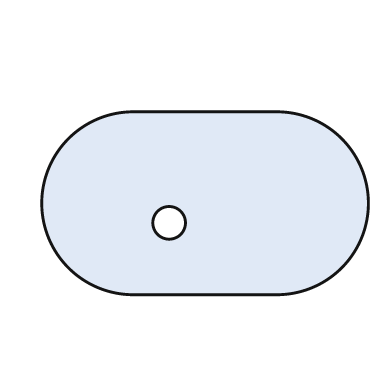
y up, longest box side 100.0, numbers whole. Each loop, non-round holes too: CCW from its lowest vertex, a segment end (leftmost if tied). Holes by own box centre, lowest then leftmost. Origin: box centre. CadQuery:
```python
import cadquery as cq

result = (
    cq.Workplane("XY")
    .moveTo(-22.0, -28.0)
    .lineTo(22.0, -28.0)
    .threePointArc((50.0, 0.0), (22.0, 28.0))
    .lineTo(-22.0, 28.0)
    .threePointArc((-50.0, 0.0), (-22.0, -28.0))
    .close()
    .moveTo(-11.0, -6.0)
    .circle(5.0)
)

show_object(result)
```